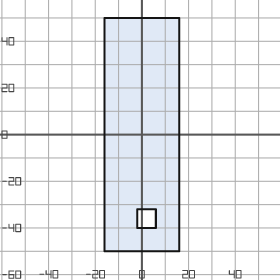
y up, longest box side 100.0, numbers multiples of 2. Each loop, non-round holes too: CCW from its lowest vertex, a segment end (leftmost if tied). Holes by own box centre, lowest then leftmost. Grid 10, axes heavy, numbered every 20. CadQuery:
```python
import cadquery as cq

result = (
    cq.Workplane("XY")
    .moveTo(-16.0, -50.0)
    .lineTo(16.0, -50.0)
    .lineTo(16.0, 50.0)
    .lineTo(-16.0, 50.0)
    .close()
    .moveTo(-2.0, -40.0)
    .lineTo(6.0, -40.0)
    .lineTo(6.0, -32.0)
    .lineTo(-2.0, -32.0)
    .close()
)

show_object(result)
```